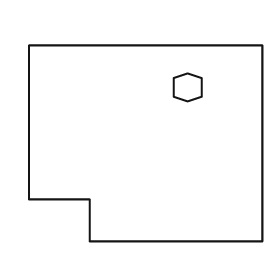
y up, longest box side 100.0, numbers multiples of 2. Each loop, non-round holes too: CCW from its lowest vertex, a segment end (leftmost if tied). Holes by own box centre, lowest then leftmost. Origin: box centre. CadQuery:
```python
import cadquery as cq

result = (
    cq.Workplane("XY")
    .moveTo(-24.0, -42.0)
    .lineTo(50.0, -42.0)
    .lineTo(50.0, 42.0)
    .lineTo(-50.0, 42.0)
    .lineTo(-50.0, -24.0)
    .lineTo(-24.0, -24.0)
    .close()
    .moveTo(18.0, 18.0)
    .lineTo(24.0, 20.0)
    .lineTo(24.0, 28.0)
    .lineTo(18.0, 30.0)
    .lineTo(12.0, 28.0)
    .lineTo(12.0, 20.0)
    .close()
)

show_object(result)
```